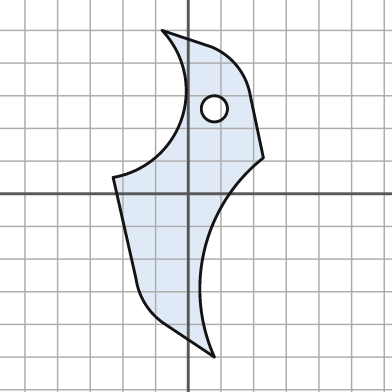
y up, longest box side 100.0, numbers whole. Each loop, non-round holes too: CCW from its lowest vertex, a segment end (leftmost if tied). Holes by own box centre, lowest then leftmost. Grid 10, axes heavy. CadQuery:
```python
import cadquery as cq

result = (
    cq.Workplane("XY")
    .moveTo(8.0, -50.0)
    .threePointArc((5.0, -17.0), (23.0, 11.0))
    .lineTo(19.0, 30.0)
    .threePointArc((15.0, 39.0), (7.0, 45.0))
    .lineTo(-8.0, 50.0)
    .threePointArc((-2.0, 23.0), (-23.0, 5.0))
    .lineTo(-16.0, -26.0)
    .threePointArc((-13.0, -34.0), (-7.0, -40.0))
    .close()
    .moveTo(8.0, 26.0)
    .circle(4.0)
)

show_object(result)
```